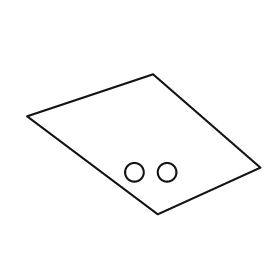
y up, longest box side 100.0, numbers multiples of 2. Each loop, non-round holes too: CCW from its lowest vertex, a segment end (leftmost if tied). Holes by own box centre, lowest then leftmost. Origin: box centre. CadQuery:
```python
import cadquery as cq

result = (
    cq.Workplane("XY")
    .moveTo(6.0, -30.0)
    .lineTo(50.0, -10.0)
    .lineTo(4.0, 30.0)
    .lineTo(-50.0, 12.0)
    .close()
    .moveTo(-4.0, -12.0)
    .circle(4.0)
    .moveTo(10.0, -12.0)
    .circle(4.0)
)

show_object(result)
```